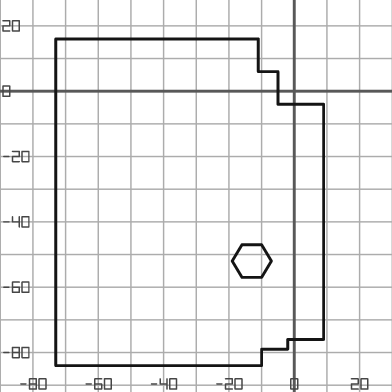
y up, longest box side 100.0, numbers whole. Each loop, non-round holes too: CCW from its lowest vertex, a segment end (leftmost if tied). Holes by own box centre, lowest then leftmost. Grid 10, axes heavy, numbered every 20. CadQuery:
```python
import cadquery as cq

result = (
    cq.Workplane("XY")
    .moveTo(-73.0, -84.0)
    .lineTo(-10.0, -84.0)
    .lineTo(-10.0, -79.0)
    .lineTo(-2.0, -79.0)
    .lineTo(-2.0, -76.0)
    .lineTo(9.0, -76.0)
    .lineTo(9.0, -4.0)
    .lineTo(-5.0, -4.0)
    .lineTo(-5.0, 6.0)
    .lineTo(-11.0, 6.0)
    .lineTo(-11.0, 16.0)
    .lineTo(-73.0, 16.0)
    .close()
    .moveTo(-16.0, -57.0)
    .lineTo(-10.0, -57.0)
    .lineTo(-7.0, -52.0)
    .lineTo(-10.0, -47.0)
    .lineTo(-16.0, -47.0)
    .lineTo(-19.0, -52.0)
    .close()
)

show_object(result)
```